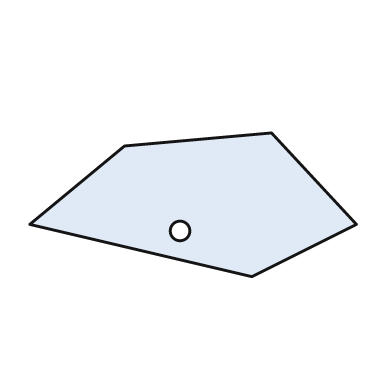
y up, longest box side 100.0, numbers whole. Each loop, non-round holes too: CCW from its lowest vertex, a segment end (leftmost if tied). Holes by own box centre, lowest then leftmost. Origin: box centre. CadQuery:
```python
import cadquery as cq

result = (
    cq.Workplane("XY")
    .moveTo(18.0, -22.0)
    .lineTo(50.0, -6.0)
    .lineTo(24.0, 22.0)
    .lineTo(-21.0, 18.0)
    .lineTo(-50.0, -6.0)
    .close()
    .moveTo(-4.0, -8.0)
    .circle(3.0)
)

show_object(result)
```